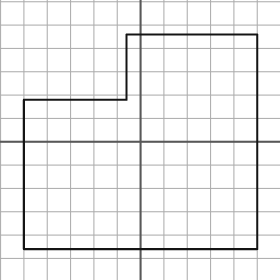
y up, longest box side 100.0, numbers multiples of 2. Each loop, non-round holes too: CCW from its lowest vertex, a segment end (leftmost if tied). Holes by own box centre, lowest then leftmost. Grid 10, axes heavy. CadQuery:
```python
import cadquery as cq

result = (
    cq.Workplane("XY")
    .moveTo(-50.0, -46.0)
    .lineTo(50.0, -46.0)
    .lineTo(50.0, 46.0)
    .lineTo(-6.0, 46.0)
    .lineTo(-6.0, 18.0)
    .lineTo(-50.0, 18.0)
    .close()
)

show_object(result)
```